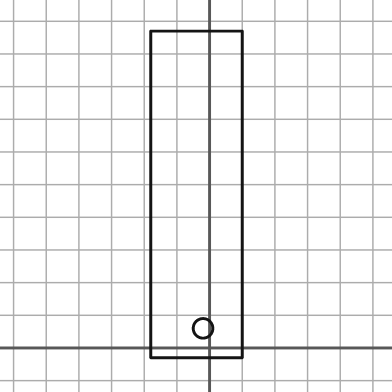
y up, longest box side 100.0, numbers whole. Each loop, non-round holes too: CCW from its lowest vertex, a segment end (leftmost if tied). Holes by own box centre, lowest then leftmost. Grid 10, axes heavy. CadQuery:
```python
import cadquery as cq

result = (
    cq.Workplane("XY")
    .moveTo(-18.0, -3.0)
    .lineTo(10.0, -3.0)
    .lineTo(10.0, 97.0)
    .lineTo(-18.0, 97.0)
    .close()
    .moveTo(-2.0, 6.0)
    .circle(3.0)
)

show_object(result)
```